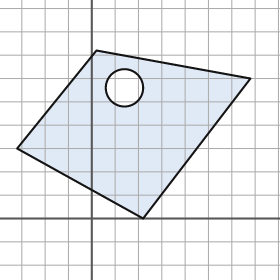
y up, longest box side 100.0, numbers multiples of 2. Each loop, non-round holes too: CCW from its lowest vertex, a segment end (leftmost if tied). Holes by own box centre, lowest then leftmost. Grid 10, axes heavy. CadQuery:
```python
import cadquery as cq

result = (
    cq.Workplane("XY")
    .moveTo(22.0, 0.0)
    .lineTo(68.0, 60.0)
    .lineTo(2.0, 72.0)
    .lineTo(-32.0, 30.0)
    .close()
    .moveTo(14.0, 56.0)
    .circle(8.0)
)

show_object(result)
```